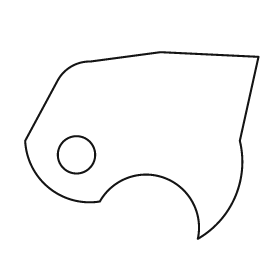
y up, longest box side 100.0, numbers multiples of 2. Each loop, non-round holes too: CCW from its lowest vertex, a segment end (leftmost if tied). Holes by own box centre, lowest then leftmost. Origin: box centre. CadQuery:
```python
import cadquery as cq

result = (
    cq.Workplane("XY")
    .moveTo(24.0, -40.0)
    .threePointArc((40.0, -22.0), (42.0, 2.0))
    .lineTo(50.0, 38.0)
    .lineTo(8.0, 40.0)
    .lineTo(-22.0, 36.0)
    .threePointArc((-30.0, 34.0), (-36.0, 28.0))
    .lineTo(-50.0, 2.0)
    .threePointArc((-40.0, -18.0), (-18.0, -24.0))
    .threePointArc((10.0, -14.0), (24.0, -40.0))
    .close()
    .moveTo(-28.0, -4.0)
    .circle(8.0)
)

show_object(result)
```